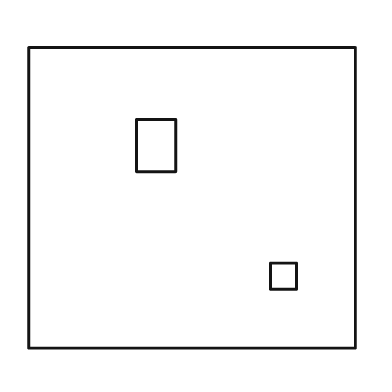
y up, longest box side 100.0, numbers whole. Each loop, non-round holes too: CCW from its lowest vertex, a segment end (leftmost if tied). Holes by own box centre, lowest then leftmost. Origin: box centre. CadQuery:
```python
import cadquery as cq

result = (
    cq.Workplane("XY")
    .moveTo(-50.0, -46.0)
    .lineTo(50.0, -46.0)
    .lineTo(50.0, 46.0)
    .lineTo(-50.0, 46.0)
    .close()
    .moveTo(24.0, -28.0)
    .lineTo(32.0, -28.0)
    .lineTo(32.0, -20.0)
    .lineTo(24.0, -20.0)
    .close()
    .moveTo(-17.0, 8.0)
    .lineTo(-5.0, 8.0)
    .lineTo(-5.0, 24.0)
    .lineTo(-17.0, 24.0)
    .close()
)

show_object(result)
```